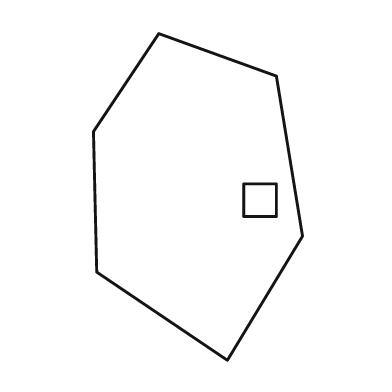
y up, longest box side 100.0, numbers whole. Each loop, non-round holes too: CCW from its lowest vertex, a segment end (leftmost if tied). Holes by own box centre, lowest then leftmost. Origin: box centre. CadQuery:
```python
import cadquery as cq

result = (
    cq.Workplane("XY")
    .moveTo(9.0, -50.0)
    .lineTo(32.0, -12.0)
    .lineTo(24.0, 37.0)
    .lineTo(-12.0, 50.0)
    .lineTo(-32.0, 20.0)
    .lineTo(-31.0, -23.0)
    .close()
    .moveTo(14.0, -6.0)
    .lineTo(24.0, -6.0)
    .lineTo(24.0, 4.0)
    .lineTo(14.0, 4.0)
    .close()
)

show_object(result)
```